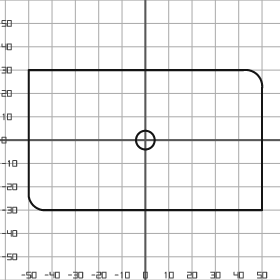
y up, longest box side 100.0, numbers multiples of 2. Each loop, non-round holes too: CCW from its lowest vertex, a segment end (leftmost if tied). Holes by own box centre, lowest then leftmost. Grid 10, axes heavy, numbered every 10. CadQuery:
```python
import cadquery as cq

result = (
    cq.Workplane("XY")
    .moveTo(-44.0, -30.0)
    .lineTo(50.0, -30.0)
    .lineTo(50.0, 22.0)
    .threePointArc((48.0, 28.0), (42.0, 30.0))
    .lineTo(-50.0, 30.0)
    .lineTo(-50.0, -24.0)
    .threePointArc((-48.0, -28.0), (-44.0, -30.0))
    .close()
    .moveTo(0.0, 0.0)
    .circle(4.0)
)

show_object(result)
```